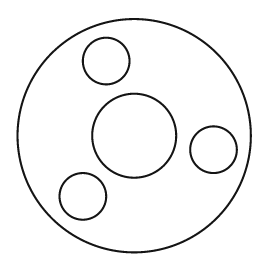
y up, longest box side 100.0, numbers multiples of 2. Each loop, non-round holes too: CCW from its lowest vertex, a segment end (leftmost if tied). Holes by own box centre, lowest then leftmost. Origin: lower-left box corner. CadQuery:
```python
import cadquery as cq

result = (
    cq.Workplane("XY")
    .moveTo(50.0, 50.0)
    .circle(50.0)
    .moveTo(28.0, 24.0)
    .circle(10.0)
    .moveTo(84.0, 44.0)
    .circle(10.0)
    .moveTo(50.0, 50.0)
    .circle(18.0)
    .moveTo(38.0, 82.0)
    .circle(10.0)
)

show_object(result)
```